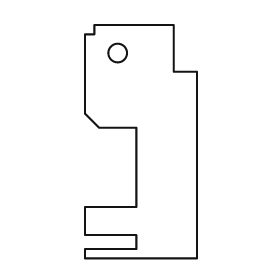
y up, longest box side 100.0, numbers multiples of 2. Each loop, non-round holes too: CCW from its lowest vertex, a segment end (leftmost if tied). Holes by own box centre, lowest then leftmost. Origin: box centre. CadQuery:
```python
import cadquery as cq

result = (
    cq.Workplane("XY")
    .moveTo(-24.0, -50.0)
    .lineTo(24.0, -50.0)
    .lineTo(24.0, 30.0)
    .lineTo(14.0, 30.0)
    .lineTo(14.0, 50.0)
    .lineTo(-20.0, 50.0)
    .lineTo(-20.0, 46.0)
    .lineTo(-24.0, 46.0)
    .lineTo(-24.0, 12.0)
    .lineTo(-18.0, 6.0)
    .lineTo(-2.0, 6.0)
    .lineTo(-2.0, -28.0)
    .lineTo(-24.0, -28.0)
    .lineTo(-24.0, -40.0)
    .lineTo(-2.0, -40.0)
    .lineTo(-2.0, -46.0)
    .lineTo(-24.0, -46.0)
    .close()
    .moveTo(-10.0, 38.0)
    .circle(4.0)
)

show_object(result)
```